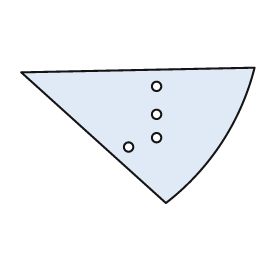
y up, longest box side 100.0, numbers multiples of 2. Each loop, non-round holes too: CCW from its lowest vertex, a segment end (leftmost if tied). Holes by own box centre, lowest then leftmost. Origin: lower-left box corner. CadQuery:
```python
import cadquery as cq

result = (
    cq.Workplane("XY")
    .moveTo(62.0, 0.0)
    .threePointArc((86.0, 26.0), (100.0, 58.0))
    .lineTo(0.0, 56.0)
    .close()
    .moveTo(46.0, 24.0)
    .circle(2.0)
    .moveTo(58.0, 28.0)
    .circle(2.0)
    .moveTo(58.0, 38.0)
    .circle(2.0)
    .moveTo(58.0, 50.0)
    .circle(2.0)
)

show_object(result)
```